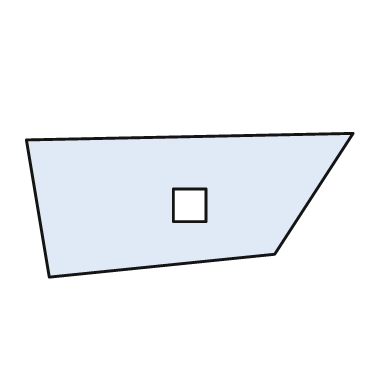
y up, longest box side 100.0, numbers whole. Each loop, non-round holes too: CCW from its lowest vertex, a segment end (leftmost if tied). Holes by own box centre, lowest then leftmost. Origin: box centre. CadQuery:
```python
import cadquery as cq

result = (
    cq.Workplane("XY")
    .moveTo(-43.0, -22.0)
    .lineTo(26.0, -15.0)
    .lineTo(50.0, 22.0)
    .lineTo(-50.0, 20.0)
    .close()
    .moveTo(-5.0, -5.0)
    .lineTo(5.0, -5.0)
    .lineTo(5.0, 5.0)
    .lineTo(-5.0, 5.0)
    .close()
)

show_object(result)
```